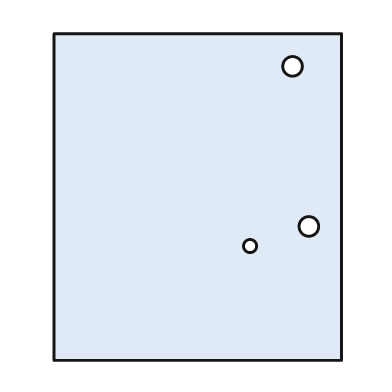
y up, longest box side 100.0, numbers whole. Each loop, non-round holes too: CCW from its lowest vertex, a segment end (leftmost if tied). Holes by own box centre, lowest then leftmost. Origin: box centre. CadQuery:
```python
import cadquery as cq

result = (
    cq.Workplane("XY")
    .moveTo(-44.0, -50.0)
    .lineTo(44.0, -50.0)
    .lineTo(44.0, 50.0)
    .lineTo(-44.0, 50.0)
    .close()
    .moveTo(16.0, -15.0)
    .circle(2.0)
    .moveTo(34.0, -9.0)
    .circle(3.0)
    .moveTo(29.0, 40.0)
    .circle(3.0)
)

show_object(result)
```